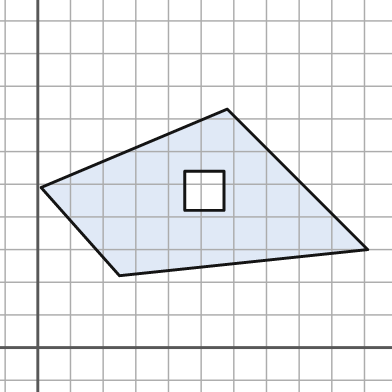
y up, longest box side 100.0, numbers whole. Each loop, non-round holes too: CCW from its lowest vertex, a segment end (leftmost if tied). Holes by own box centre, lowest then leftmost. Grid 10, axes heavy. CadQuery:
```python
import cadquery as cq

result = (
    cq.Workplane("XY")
    .moveTo(25.0, 22.0)
    .lineTo(101.0, 30.0)
    .lineTo(58.0, 73.0)
    .lineTo(1.0, 49.0)
    .close()
    .moveTo(45.0, 42.0)
    .lineTo(57.0, 42.0)
    .lineTo(57.0, 54.0)
    .lineTo(45.0, 54.0)
    .close()
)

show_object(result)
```